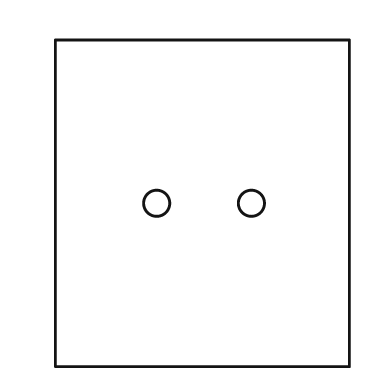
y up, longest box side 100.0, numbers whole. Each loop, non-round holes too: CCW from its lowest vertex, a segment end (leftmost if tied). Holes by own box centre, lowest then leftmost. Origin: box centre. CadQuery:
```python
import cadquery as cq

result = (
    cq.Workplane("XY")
    .moveTo(-45.0, -50.0)
    .lineTo(45.0, -50.0)
    .lineTo(45.0, 50.0)
    .lineTo(-45.0, 50.0)
    .close()
    .moveTo(-14.0, 0.0)
    .circle(4.0)
    .moveTo(15.0, 0.0)
    .circle(4.0)
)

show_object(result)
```